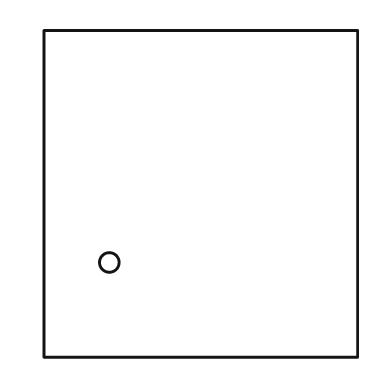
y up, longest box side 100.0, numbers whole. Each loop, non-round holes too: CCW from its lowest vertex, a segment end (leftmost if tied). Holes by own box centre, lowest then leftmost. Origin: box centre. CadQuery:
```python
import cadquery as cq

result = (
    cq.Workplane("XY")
    .moveTo(-48.0, -50.0)
    .lineTo(48.0, -50.0)
    .lineTo(48.0, 50.0)
    .lineTo(-48.0, 50.0)
    .close()
    .moveTo(-28.0, -21.0)
    .circle(3.0)
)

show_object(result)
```